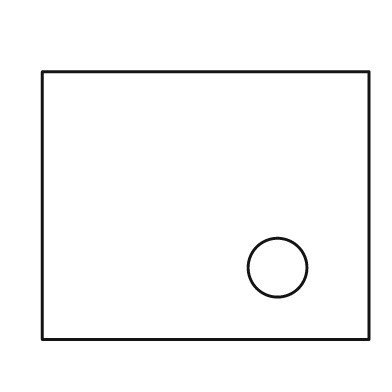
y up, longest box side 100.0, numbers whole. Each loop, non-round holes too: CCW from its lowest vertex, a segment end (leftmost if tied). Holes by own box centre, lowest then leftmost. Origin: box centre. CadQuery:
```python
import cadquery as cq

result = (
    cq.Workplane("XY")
    .moveTo(-50.0, -41.0)
    .lineTo(50.0, -41.0)
    .lineTo(50.0, 41.0)
    .lineTo(-50.0, 41.0)
    .close()
    .moveTo(22.0, -19.0)
    .circle(9.0)
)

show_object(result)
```